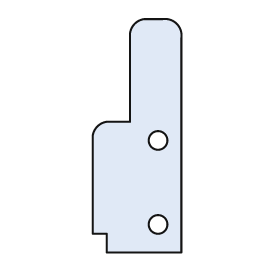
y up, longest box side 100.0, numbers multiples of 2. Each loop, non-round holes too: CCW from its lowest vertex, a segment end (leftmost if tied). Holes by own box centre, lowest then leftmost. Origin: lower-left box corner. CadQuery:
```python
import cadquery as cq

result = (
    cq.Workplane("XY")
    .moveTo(6.0, 0.0)
    .lineTo(38.0, 0.0)
    .lineTo(38.0, 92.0)
    .threePointArc((36.0, 98.0), (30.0, 100.0))
    .lineTo(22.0, 100.0)
    .threePointArc((18.0, 98.0), (16.0, 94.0))
    .lineTo(16.0, 56.0)
    .lineTo(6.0, 56.0)
    .threePointArc((2.0, 54.0), (0.0, 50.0))
    .lineTo(0.0, 8.0)
    .lineTo(6.0, 8.0)
    .close()
    .moveTo(28.0, 12.0)
    .circle(4.0)
    .moveTo(28.0, 48.0)
    .circle(4.0)
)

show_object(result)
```